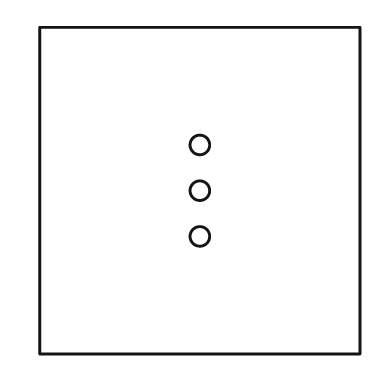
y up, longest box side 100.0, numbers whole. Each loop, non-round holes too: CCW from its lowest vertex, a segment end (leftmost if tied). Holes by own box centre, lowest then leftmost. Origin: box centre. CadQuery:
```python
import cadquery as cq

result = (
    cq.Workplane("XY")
    .moveTo(-49.0, -50.0)
    .lineTo(49.0, -50.0)
    .lineTo(49.0, 50.0)
    .lineTo(-49.0, 50.0)
    .close()
    .moveTo(0.0, -14.0)
    .circle(3.0)
    .moveTo(0.0, 0.0)
    .circle(3.0)
    .moveTo(0.0, 14.0)
    .circle(3.0)
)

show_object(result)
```